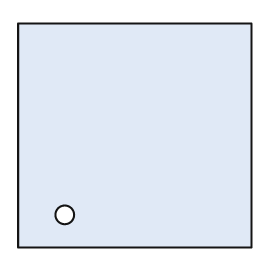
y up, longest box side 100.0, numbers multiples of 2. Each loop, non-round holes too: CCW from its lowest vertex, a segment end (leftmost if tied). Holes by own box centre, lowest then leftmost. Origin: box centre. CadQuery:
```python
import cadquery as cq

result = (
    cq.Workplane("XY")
    .moveTo(-50.0, -48.0)
    .lineTo(50.0, -48.0)
    .lineTo(50.0, 48.0)
    .lineTo(-50.0, 48.0)
    .close()
    .moveTo(-30.0, -34.0)
    .circle(4.0)
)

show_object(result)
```